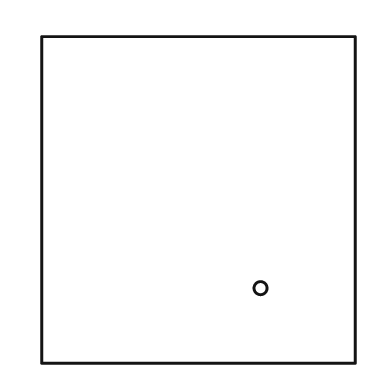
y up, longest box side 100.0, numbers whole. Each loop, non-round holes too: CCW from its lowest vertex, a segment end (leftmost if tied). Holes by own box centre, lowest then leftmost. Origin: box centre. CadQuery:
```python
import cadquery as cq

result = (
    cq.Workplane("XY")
    .moveTo(-48.0, -50.0)
    .lineTo(48.0, -50.0)
    .lineTo(48.0, 50.0)
    .lineTo(-48.0, 50.0)
    .close()
    .moveTo(19.0, -27.0)
    .circle(2.0)
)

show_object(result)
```